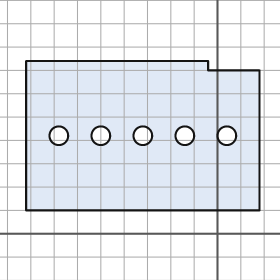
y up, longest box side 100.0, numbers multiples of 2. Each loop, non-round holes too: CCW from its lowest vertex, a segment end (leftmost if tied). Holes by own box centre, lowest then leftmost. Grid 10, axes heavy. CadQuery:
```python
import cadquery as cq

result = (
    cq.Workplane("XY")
    .moveTo(-82.0, 10.0)
    .lineTo(18.0, 10.0)
    .lineTo(18.0, 70.0)
    .lineTo(-4.0, 70.0)
    .lineTo(-4.0, 74.0)
    .lineTo(-82.0, 74.0)
    .close()
    .moveTo(-68.0, 42.0)
    .circle(4.0)
    .moveTo(-50.0, 42.0)
    .circle(4.0)
    .moveTo(-32.0, 42.0)
    .circle(4.0)
    .moveTo(-14.0, 42.0)
    .circle(4.0)
    .moveTo(4.0, 42.0)
    .circle(4.0)
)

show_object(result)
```